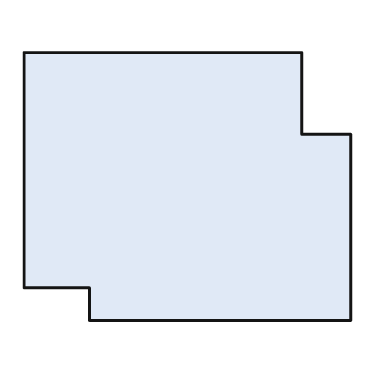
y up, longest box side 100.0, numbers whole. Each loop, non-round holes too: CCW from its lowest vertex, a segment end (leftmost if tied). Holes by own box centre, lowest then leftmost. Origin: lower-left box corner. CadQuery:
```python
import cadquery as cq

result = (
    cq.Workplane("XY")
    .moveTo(20.0, 0.0)
    .lineTo(100.0, 0.0)
    .lineTo(100.0, 57.0)
    .lineTo(85.0, 57.0)
    .lineTo(85.0, 82.0)
    .lineTo(0.0, 82.0)
    .lineTo(0.0, 10.0)
    .lineTo(20.0, 10.0)
    .close()
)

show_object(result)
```